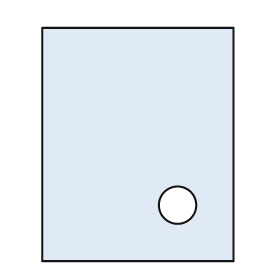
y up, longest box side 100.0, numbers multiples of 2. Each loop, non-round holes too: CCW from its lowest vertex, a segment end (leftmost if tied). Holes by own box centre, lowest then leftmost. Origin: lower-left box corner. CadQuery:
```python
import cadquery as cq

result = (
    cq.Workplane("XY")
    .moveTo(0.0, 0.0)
    .lineTo(82.0, 0.0)
    .lineTo(82.0, 100.0)
    .lineTo(0.0, 100.0)
    .close()
    .moveTo(58.0, 24.0)
    .circle(8.0)
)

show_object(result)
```